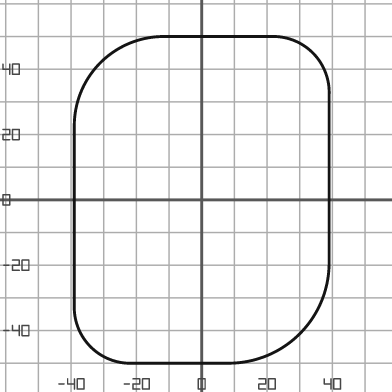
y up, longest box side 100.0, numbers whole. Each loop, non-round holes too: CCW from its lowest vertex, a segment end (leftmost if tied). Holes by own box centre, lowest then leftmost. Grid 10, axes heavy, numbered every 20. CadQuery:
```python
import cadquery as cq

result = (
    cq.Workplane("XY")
    .moveTo(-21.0, -50.0)
    .lineTo(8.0, -50.0)
    .threePointArc((30.0, -41.0), (39.0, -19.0))
    .lineTo(39.0, 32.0)
    .threePointArc((34.0, 45.0), (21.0, 50.0))
    .lineTo(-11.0, 50.0)
    .threePointArc((-31.0, 42.0), (-39.0, 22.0))
    .lineTo(-39.0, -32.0)
    .threePointArc((-34.0, -45.0), (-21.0, -50.0))
    .close()
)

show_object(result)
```